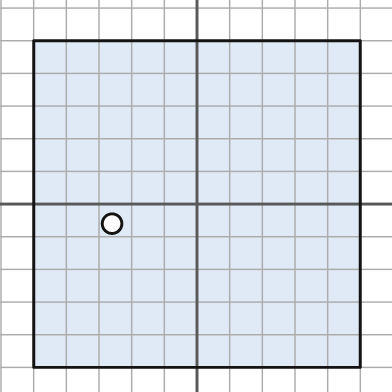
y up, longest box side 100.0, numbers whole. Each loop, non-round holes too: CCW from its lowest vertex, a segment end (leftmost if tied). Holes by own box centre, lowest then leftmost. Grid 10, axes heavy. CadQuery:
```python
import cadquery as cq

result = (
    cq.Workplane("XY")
    .moveTo(-50.0, -50.0)
    .lineTo(50.0, -50.0)
    .lineTo(50.0, 50.0)
    .lineTo(-50.0, 50.0)
    .close()
    .moveTo(-26.0, -6.0)
    .circle(3.0)
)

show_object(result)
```